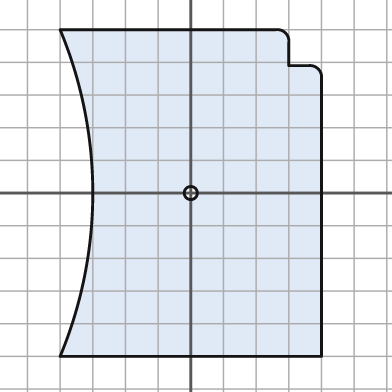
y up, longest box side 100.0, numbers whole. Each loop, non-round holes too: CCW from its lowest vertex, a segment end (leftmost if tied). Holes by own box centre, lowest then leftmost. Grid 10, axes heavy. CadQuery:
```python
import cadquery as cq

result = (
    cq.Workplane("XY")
    .moveTo(-40.0, -50.0)
    .lineTo(40.0, -50.0)
    .lineTo(40.0, 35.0)
    .threePointArc((39.0, 38.0), (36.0, 39.0))
    .lineTo(30.0, 39.0)
    .lineTo(30.0, 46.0)
    .threePointArc((29.0, 49.0), (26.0, 50.0))
    .lineTo(-40.0, 50.0)
    .threePointArc((-30.0, 0.0), (-40.0, -50.0))
    .close()
    .moveTo(0.0, 0.0)
    .circle(2.0)
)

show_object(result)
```